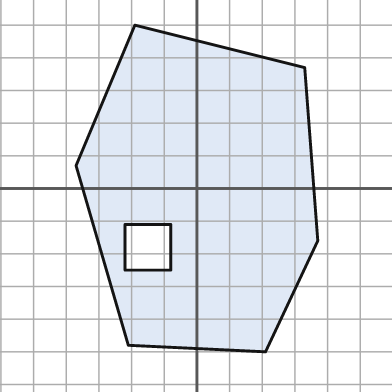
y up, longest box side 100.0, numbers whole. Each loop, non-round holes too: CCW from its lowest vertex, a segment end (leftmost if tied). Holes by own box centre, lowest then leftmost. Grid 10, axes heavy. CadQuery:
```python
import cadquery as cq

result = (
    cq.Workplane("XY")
    .moveTo(21.0, -50.0)
    .lineTo(37.0, -16.0)
    .lineTo(33.0, 37.0)
    .lineTo(-19.0, 50.0)
    .lineTo(-37.0, 7.0)
    .lineTo(-21.0, -48.0)
    .close()
    .moveTo(-22.0, -25.0)
    .lineTo(-8.0, -25.0)
    .lineTo(-8.0, -11.0)
    .lineTo(-22.0, -11.0)
    .close()
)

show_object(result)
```